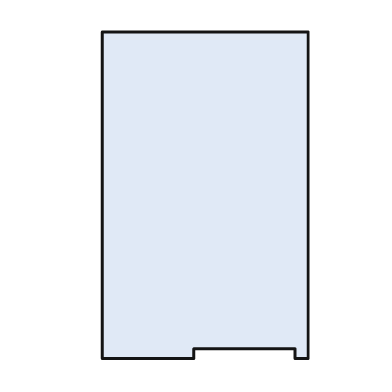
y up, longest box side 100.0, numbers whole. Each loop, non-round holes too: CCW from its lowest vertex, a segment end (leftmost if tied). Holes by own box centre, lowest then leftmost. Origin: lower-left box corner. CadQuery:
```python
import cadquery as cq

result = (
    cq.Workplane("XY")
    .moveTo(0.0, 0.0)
    .lineTo(28.0, 0.0)
    .lineTo(28.0, 3.0)
    .lineTo(59.0, 3.0)
    .lineTo(59.0, 0.0)
    .lineTo(63.0, 0.0)
    .lineTo(63.0, 100.0)
    .lineTo(0.0, 100.0)
    .close()
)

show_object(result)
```